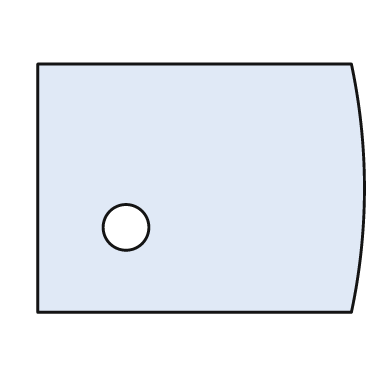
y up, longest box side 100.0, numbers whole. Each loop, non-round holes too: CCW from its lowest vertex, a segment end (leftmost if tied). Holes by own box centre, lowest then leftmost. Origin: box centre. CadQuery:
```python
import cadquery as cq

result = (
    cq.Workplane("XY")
    .moveTo(-50.0, -38.0)
    .lineTo(46.0, -38.0)
    .threePointArc((50.0, 0.0), (46.0, 38.0))
    .lineTo(-50.0, 38.0)
    .close()
    .moveTo(-23.0, -12.0)
    .circle(7.0)
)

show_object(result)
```